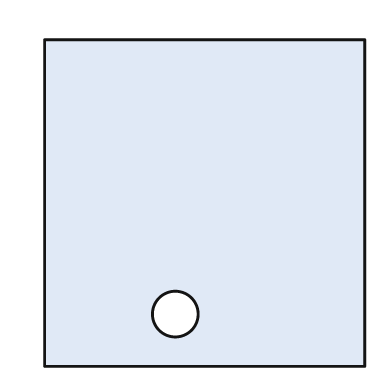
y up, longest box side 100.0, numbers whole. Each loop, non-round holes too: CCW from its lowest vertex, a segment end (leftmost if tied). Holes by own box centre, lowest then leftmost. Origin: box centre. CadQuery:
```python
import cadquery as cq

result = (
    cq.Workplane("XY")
    .moveTo(-49.0, -50.0)
    .lineTo(49.0, -50.0)
    .lineTo(49.0, 50.0)
    .lineTo(-49.0, 50.0)
    .close()
    .moveTo(-9.0, -34.0)
    .circle(7.0)
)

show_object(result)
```